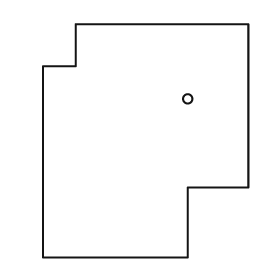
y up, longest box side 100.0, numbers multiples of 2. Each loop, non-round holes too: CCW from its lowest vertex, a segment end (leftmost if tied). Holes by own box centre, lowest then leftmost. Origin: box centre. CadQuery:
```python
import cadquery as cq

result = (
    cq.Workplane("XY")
    .moveTo(-44.0, -50.0)
    .lineTo(18.0, -50.0)
    .lineTo(18.0, -20.0)
    .lineTo(44.0, -20.0)
    .lineTo(44.0, 50.0)
    .lineTo(-30.0, 50.0)
    .lineTo(-30.0, 32.0)
    .lineTo(-44.0, 32.0)
    .close()
    .moveTo(18.0, 18.0)
    .circle(2.0)
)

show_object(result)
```